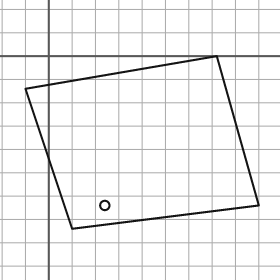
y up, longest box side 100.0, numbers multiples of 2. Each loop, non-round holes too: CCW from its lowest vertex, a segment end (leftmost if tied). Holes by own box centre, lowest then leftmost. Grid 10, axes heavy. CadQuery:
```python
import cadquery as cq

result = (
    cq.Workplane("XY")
    .moveTo(10.0, -74.0)
    .lineTo(90.0, -64.0)
    .lineTo(72.0, 0.0)
    .lineTo(-10.0, -14.0)
    .close()
    .moveTo(24.0, -64.0)
    .circle(2.0)
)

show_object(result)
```